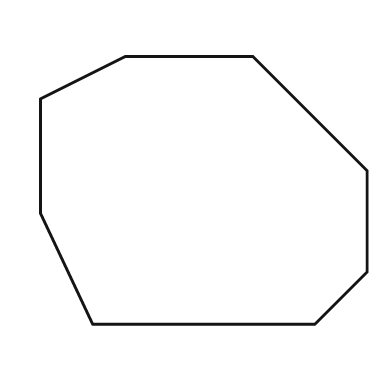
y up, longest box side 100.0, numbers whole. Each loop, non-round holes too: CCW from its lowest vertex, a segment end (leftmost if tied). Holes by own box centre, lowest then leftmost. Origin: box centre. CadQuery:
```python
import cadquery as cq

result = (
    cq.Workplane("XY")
    .moveTo(-34.0, -41.0)
    .lineTo(34.0, -41.0)
    .lineTo(50.0, -25.0)
    .lineTo(50.0, 6.0)
    .lineTo(15.0, 41.0)
    .lineTo(-24.0, 41.0)
    .lineTo(-50.0, 28.0)
    .lineTo(-50.0, -7.0)
    .close()
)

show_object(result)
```